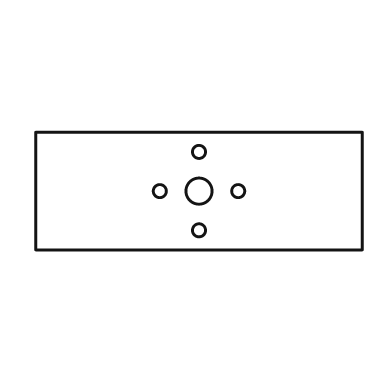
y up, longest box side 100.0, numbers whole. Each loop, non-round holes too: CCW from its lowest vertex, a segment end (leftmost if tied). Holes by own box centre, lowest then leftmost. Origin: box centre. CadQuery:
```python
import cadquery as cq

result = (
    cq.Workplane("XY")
    .moveTo(-50.0, -18.0)
    .lineTo(50.0, -18.0)
    .lineTo(50.0, 18.0)
    .lineTo(-50.0, 18.0)
    .close()
    .moveTo(0.0, -12.0)
    .circle(2.0)
    .moveTo(-12.0, 0.0)
    .circle(2.0)
    .moveTo(0.0, 0.0)
    .circle(4.0)
    .moveTo(12.0, 0.0)
    .circle(2.0)
    .moveTo(0.0, 12.0)
    .circle(2.0)
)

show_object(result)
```